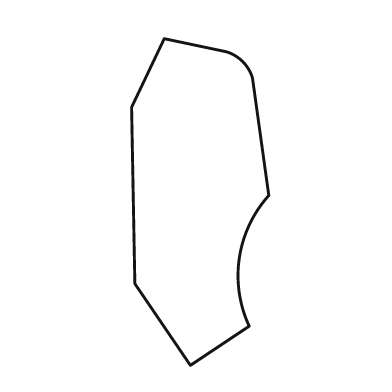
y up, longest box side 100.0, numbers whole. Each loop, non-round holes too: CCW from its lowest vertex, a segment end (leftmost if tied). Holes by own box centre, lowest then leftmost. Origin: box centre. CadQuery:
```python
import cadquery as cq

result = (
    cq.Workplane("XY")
    .moveTo(-3.0, -50.0)
    .lineTo(15.0, -38.0)
    .threePointArc((12.0, -17.0), (21.0, 2.0))
    .lineTo(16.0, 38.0)
    .threePointArc((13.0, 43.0), (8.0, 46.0))
    .lineTo(-11.0, 50.0)
    .lineTo(-21.0, 29.0)
    .lineTo(-20.0, -25.0)
    .close()
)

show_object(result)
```